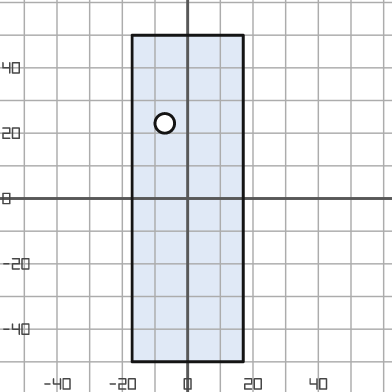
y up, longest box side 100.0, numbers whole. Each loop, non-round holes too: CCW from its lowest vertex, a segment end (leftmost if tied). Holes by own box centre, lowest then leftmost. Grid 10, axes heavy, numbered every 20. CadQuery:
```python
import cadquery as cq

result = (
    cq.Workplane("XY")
    .moveTo(-17.0, -50.0)
    .lineTo(17.0, -50.0)
    .lineTo(17.0, 50.0)
    .lineTo(-17.0, 50.0)
    .close()
    .moveTo(-7.0, 23.0)
    .circle(3.0)
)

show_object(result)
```